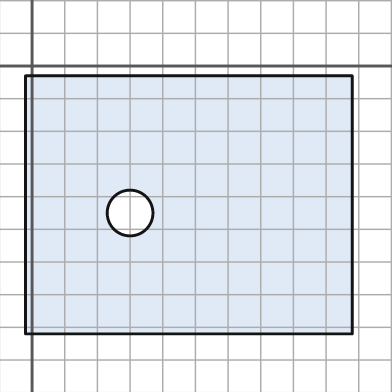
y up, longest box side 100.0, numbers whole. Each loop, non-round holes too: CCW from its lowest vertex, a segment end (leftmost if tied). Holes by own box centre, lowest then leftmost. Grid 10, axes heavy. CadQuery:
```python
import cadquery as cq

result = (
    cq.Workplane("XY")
    .moveTo(-2.0, -82.0)
    .lineTo(98.0, -82.0)
    .lineTo(98.0, -3.0)
    .lineTo(-2.0, -3.0)
    .close()
    .moveTo(30.0, -45.0)
    .circle(7.0)
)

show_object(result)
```